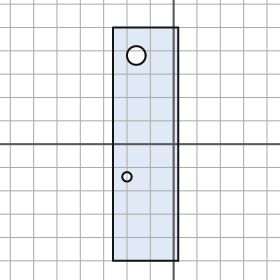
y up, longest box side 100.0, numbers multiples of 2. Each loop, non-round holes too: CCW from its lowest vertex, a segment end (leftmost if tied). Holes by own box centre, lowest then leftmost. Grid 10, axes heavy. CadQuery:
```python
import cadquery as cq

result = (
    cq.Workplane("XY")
    .moveTo(-26.0, -50.0)
    .lineTo(2.0, -50.0)
    .lineTo(2.0, 50.0)
    .lineTo(-26.0, 50.0)
    .close()
    .moveTo(-20.0, -14.0)
    .circle(2.0)
    .moveTo(-16.0, 38.0)
    .circle(4.0)
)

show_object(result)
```